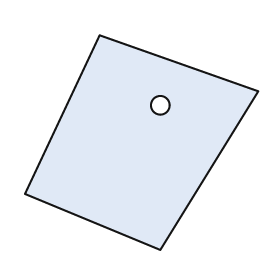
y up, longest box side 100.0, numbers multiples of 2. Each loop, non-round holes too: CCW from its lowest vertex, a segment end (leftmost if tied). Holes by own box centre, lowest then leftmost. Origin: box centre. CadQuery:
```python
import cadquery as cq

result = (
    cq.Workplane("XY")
    .moveTo(8.0, -46.0)
    .lineTo(50.0, 22.0)
    .lineTo(-18.0, 46.0)
    .lineTo(-50.0, -22.0)
    .close()
    .moveTo(8.0, 16.0)
    .circle(4.0)
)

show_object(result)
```